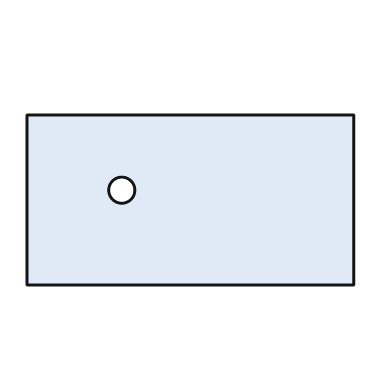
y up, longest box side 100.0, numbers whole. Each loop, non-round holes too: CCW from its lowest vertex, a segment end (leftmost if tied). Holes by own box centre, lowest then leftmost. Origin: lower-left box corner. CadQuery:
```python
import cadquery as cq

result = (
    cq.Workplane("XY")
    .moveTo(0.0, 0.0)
    .lineTo(100.0, 0.0)
    .lineTo(100.0, 52.0)
    .lineTo(0.0, 52.0)
    .close()
    .moveTo(29.0, 29.0)
    .circle(4.0)
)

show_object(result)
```